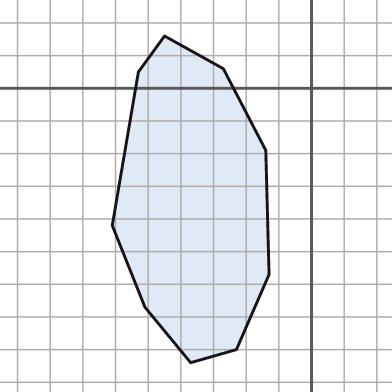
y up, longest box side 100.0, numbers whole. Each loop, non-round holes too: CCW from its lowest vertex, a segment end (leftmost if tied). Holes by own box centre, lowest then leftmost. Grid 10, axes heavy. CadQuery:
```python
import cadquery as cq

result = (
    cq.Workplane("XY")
    .moveTo(-37.0, -84.0)
    .lineTo(-23.0, -80.0)
    .lineTo(-13.0, -57.0)
    .lineTo(-14.0, -19.0)
    .lineTo(-27.0, 6.0)
    .lineTo(-45.0, 16.0)
    .lineTo(-53.0, 5.0)
    .lineTo(-61.0, -42.0)
    .lineTo(-51.0, -67.0)
    .close()
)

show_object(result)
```